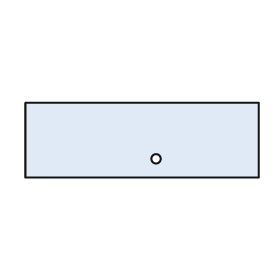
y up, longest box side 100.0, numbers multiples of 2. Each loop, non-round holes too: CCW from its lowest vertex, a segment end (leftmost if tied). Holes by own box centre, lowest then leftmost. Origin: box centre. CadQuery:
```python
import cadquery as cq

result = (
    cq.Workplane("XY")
    .moveTo(-50.0, -16.0)
    .lineTo(50.0, -16.0)
    .lineTo(50.0, 16.0)
    .lineTo(-50.0, 16.0)
    .close()
    .moveTo(6.0, -8.0)
    .circle(2.0)
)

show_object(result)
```